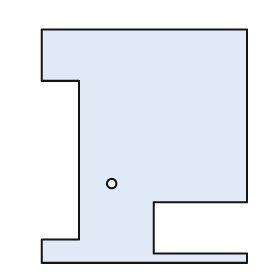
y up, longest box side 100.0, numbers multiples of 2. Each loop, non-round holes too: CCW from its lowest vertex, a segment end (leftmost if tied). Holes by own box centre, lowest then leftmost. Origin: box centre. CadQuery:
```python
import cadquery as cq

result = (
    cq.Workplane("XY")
    .moveTo(-44.0, -50.0)
    .lineTo(44.0, -50.0)
    .lineTo(44.0, -46.0)
    .lineTo(4.0, -46.0)
    .lineTo(4.0, -24.0)
    .lineTo(44.0, -24.0)
    .lineTo(44.0, 50.0)
    .lineTo(-44.0, 50.0)
    .lineTo(-44.0, 28.0)
    .lineTo(-28.0, 28.0)
    .lineTo(-28.0, -40.0)
    .lineTo(-44.0, -40.0)
    .close()
    .moveTo(-14.0, -16.0)
    .circle(2.0)
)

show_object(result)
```